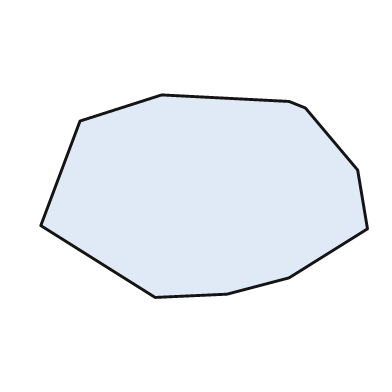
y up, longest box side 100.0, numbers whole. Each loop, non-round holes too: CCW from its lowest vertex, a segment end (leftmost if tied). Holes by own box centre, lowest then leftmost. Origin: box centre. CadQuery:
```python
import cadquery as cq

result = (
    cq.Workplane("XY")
    .moveTo(-15.0, -31.0)
    .lineTo(7.0, -30.0)
    .lineTo(26.0, -25.0)
    .lineTo(50.0, -10.0)
    .lineTo(47.0, 8.0)
    .lineTo(31.0, 27.0)
    .lineTo(26.0, 29.0)
    .lineTo(-13.0, 31.0)
    .lineTo(-38.0, 23.0)
    .lineTo(-50.0, -9.0)
    .close()
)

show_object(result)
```